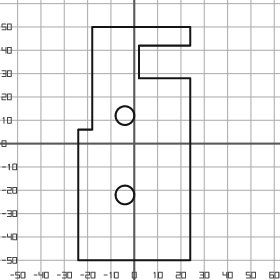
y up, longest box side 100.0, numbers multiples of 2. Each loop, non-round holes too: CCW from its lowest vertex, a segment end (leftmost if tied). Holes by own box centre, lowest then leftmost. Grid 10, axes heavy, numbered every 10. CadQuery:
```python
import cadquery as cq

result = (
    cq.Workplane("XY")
    .moveTo(-24.0, -50.0)
    .lineTo(24.0, -50.0)
    .lineTo(24.0, 28.0)
    .lineTo(2.0, 28.0)
    .lineTo(2.0, 42.0)
    .lineTo(24.0, 42.0)
    .lineTo(24.0, 50.0)
    .lineTo(-18.0, 50.0)
    .lineTo(-18.0, 6.0)
    .lineTo(-24.0, 6.0)
    .close()
    .moveTo(-4.0, -22.0)
    .circle(4.0)
    .moveTo(-4.0, 12.0)
    .circle(4.0)
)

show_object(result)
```